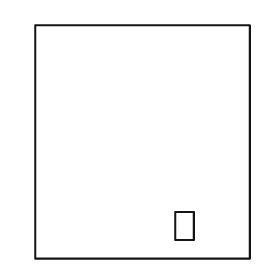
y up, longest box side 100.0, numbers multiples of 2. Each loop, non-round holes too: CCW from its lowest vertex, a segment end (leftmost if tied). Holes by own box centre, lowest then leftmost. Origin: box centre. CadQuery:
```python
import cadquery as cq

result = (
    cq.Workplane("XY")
    .moveTo(-46.0, -50.0)
    .lineTo(46.0, -50.0)
    .lineTo(46.0, 50.0)
    .lineTo(-46.0, 50.0)
    .close()
    .moveTo(14.0, -42.0)
    .lineTo(22.0, -42.0)
    .lineTo(22.0, -30.0)
    .lineTo(14.0, -30.0)
    .close()
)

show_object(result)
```